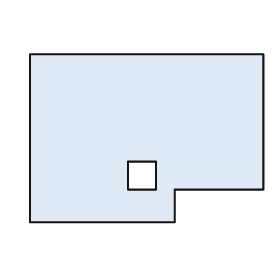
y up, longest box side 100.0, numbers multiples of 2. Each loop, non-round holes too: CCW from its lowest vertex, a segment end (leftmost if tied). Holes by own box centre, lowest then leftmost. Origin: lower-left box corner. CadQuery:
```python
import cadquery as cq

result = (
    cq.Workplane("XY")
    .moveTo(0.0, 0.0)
    .lineTo(62.0, 0.0)
    .lineTo(62.0, 14.0)
    .lineTo(100.0, 14.0)
    .lineTo(100.0, 72.0)
    .lineTo(0.0, 72.0)
    .close()
    .moveTo(42.0, 14.0)
    .lineTo(54.0, 14.0)
    .lineTo(54.0, 26.0)
    .lineTo(42.0, 26.0)
    .close()
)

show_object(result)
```